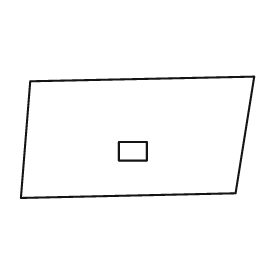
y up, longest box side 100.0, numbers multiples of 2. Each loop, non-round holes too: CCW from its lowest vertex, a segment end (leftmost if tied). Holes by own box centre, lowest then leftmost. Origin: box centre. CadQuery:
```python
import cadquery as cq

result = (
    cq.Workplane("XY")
    .moveTo(-50.0, -26.0)
    .lineTo(42.0, -24.0)
    .lineTo(50.0, 26.0)
    .lineTo(-46.0, 24.0)
    .close()
    .moveTo(-8.0, -10.0)
    .lineTo(4.0, -10.0)
    .lineTo(4.0, -2.0)
    .lineTo(-8.0, -2.0)
    .close()
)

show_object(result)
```